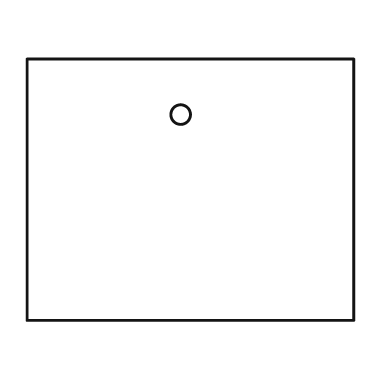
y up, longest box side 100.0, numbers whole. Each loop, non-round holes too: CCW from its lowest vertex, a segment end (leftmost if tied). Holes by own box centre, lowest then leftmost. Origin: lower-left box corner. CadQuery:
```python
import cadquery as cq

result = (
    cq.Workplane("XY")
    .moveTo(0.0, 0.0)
    .lineTo(100.0, 0.0)
    .lineTo(100.0, 80.0)
    .lineTo(0.0, 80.0)
    .close()
    .moveTo(47.0, 63.0)
    .circle(3.0)
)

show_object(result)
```